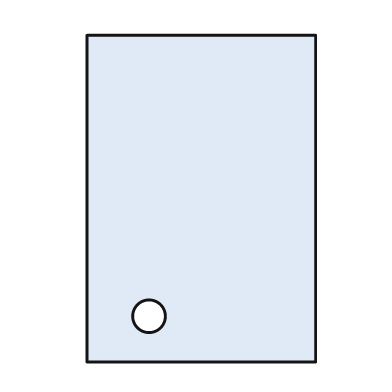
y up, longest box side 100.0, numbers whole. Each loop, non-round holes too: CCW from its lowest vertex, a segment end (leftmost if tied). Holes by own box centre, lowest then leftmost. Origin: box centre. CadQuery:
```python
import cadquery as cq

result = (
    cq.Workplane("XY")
    .moveTo(-35.0, -50.0)
    .lineTo(35.0, -50.0)
    .lineTo(35.0, 50.0)
    .lineTo(-35.0, 50.0)
    .close()
    .moveTo(-16.0, -36.0)
    .circle(5.0)
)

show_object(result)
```